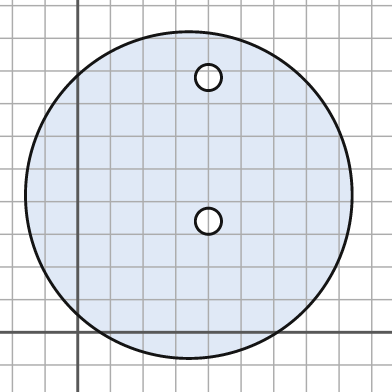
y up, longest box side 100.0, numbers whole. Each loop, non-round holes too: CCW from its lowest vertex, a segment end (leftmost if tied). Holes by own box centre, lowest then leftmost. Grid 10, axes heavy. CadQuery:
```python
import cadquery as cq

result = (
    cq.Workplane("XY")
    .moveTo(34.0, 42.0)
    .circle(50.0)
    .moveTo(40.0, 34.0)
    .circle(4.0)
    .moveTo(40.0, 78.0)
    .circle(4.0)
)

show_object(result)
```